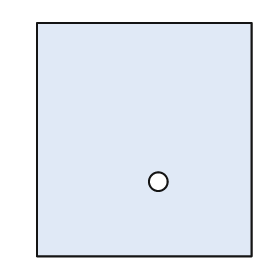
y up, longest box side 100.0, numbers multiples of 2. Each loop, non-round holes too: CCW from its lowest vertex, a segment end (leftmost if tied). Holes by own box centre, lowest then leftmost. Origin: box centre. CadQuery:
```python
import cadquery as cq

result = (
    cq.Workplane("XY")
    .moveTo(-46.0, -50.0)
    .lineTo(46.0, -50.0)
    .lineTo(46.0, 50.0)
    .lineTo(-46.0, 50.0)
    .close()
    .moveTo(6.0, -18.0)
    .circle(4.0)
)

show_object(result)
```